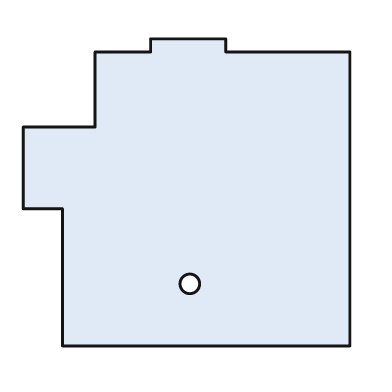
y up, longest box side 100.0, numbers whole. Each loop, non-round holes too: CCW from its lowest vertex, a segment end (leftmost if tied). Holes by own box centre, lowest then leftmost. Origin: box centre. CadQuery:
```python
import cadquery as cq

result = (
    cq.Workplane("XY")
    .moveTo(-38.0, -47.0)
    .lineTo(50.0, -47.0)
    .lineTo(50.0, 43.0)
    .lineTo(12.0, 43.0)
    .lineTo(12.0, 47.0)
    .lineTo(-11.0, 47.0)
    .lineTo(-11.0, 43.0)
    .lineTo(-28.0, 43.0)
    .lineTo(-28.0, 20.0)
    .lineTo(-50.0, 20.0)
    .lineTo(-50.0, -5.0)
    .lineTo(-38.0, -5.0)
    .close()
    .moveTo(1.0, -28.0)
    .circle(3.0)
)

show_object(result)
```